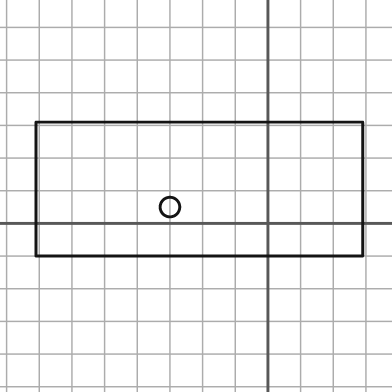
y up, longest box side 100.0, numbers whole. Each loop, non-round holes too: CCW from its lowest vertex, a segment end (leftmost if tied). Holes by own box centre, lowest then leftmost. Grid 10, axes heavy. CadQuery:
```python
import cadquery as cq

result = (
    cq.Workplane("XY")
    .moveTo(-71.0, -10.0)
    .lineTo(29.0, -10.0)
    .lineTo(29.0, 31.0)
    .lineTo(-71.0, 31.0)
    .close()
    .moveTo(-30.0, 5.0)
    .circle(3.0)
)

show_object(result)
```